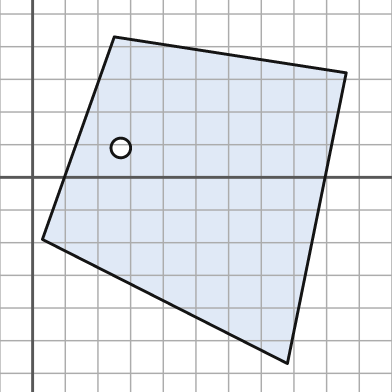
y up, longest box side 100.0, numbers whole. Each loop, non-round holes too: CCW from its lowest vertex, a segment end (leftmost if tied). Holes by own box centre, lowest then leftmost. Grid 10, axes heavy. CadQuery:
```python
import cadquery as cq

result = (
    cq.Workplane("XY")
    .moveTo(78.0, -57.0)
    .lineTo(96.0, 32.0)
    .lineTo(25.0, 43.0)
    .lineTo(3.0, -19.0)
    .close()
    .moveTo(27.0, 9.0)
    .circle(3.0)
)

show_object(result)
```